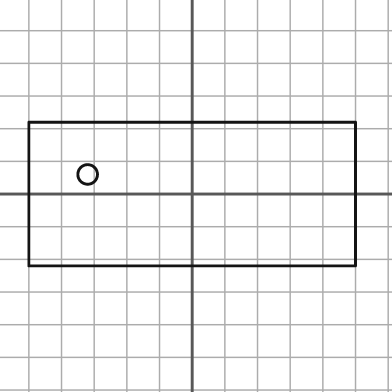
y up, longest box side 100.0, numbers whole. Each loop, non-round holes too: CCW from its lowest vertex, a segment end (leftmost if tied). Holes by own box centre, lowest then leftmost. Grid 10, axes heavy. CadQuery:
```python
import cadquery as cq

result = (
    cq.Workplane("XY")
    .moveTo(-50.0, -22.0)
    .lineTo(50.0, -22.0)
    .lineTo(50.0, 22.0)
    .lineTo(-50.0, 22.0)
    .close()
    .moveTo(-32.0, 6.0)
    .circle(3.0)
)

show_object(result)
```